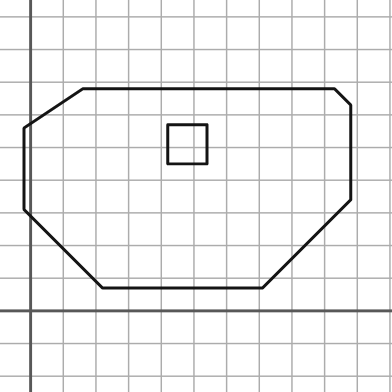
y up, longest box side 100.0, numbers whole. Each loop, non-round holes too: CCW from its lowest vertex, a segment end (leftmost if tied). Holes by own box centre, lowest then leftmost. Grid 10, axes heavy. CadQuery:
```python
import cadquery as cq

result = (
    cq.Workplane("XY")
    .moveTo(22.0, 7.0)
    .lineTo(71.0, 7.0)
    .lineTo(98.0, 34.0)
    .lineTo(98.0, 63.0)
    .lineTo(93.0, 68.0)
    .lineTo(16.0, 68.0)
    .lineTo(-2.0, 56.0)
    .lineTo(-2.0, 31.0)
    .close()
    .moveTo(42.0, 45.0)
    .lineTo(54.0, 45.0)
    .lineTo(54.0, 57.0)
    .lineTo(42.0, 57.0)
    .close()
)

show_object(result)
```